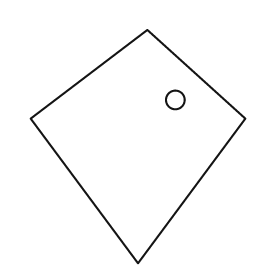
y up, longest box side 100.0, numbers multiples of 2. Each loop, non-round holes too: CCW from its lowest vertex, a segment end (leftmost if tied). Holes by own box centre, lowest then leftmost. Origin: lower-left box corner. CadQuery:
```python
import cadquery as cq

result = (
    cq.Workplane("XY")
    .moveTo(46.0, 0.0)
    .lineTo(92.0, 62.0)
    .lineTo(50.0, 100.0)
    .lineTo(0.0, 62.0)
    .close()
    .moveTo(62.0, 70.0)
    .circle(4.0)
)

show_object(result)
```